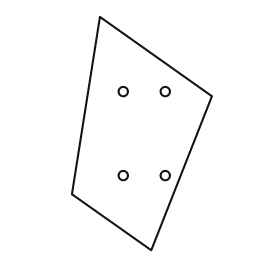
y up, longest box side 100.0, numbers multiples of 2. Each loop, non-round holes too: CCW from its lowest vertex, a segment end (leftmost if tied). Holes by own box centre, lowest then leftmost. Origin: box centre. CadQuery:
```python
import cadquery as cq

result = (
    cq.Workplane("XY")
    .moveTo(4.0, -50.0)
    .lineTo(30.0, 16.0)
    .lineTo(-18.0, 50.0)
    .lineTo(-30.0, -26.0)
    .close()
    .moveTo(-8.0, -18.0)
    .circle(2.0)
    .moveTo(10.0, -18.0)
    .circle(2.0)
    .moveTo(-8.0, 18.0)
    .circle(2.0)
    .moveTo(10.0, 18.0)
    .circle(2.0)
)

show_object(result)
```